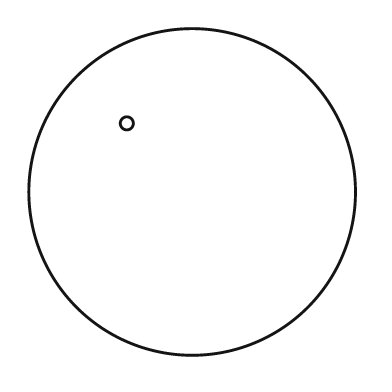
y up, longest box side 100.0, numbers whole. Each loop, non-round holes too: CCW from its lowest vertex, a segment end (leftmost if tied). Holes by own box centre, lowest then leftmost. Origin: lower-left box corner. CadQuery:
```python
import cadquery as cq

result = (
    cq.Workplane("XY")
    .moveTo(50.0, 50.0)
    .circle(50.0)
    .moveTo(30.0, 71.0)
    .circle(2.0)
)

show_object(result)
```